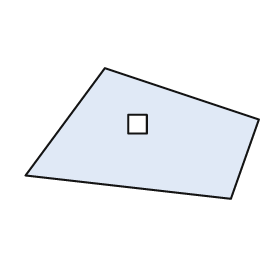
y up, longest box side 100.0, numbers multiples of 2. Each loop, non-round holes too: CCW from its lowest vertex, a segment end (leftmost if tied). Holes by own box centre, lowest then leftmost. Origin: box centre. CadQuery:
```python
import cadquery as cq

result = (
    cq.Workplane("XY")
    .moveTo(38.0, -28.0)
    .lineTo(50.0, 6.0)
    .lineTo(-16.0, 28.0)
    .lineTo(-50.0, -18.0)
    .close()
    .moveTo(-6.0, 0.0)
    .lineTo(2.0, 0.0)
    .lineTo(2.0, 8.0)
    .lineTo(-6.0, 8.0)
    .close()
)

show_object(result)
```